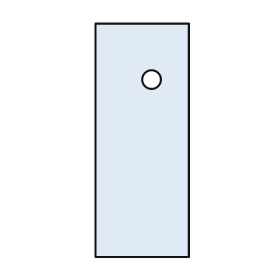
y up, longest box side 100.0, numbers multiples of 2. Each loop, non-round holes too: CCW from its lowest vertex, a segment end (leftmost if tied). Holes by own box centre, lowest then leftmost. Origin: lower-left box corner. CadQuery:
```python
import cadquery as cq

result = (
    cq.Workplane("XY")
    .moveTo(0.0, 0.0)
    .lineTo(40.0, 0.0)
    .lineTo(40.0, 100.0)
    .lineTo(0.0, 100.0)
    .close()
    .moveTo(24.0, 76.0)
    .circle(4.0)
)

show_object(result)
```